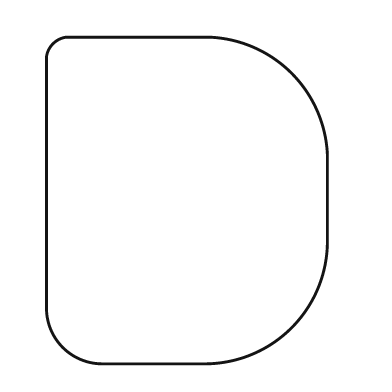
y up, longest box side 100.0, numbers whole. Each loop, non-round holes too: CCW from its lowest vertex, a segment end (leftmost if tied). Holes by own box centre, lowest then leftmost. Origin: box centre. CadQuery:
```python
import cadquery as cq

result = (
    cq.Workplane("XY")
    .moveTo(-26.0, -50.0)
    .lineTo(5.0, -50.0)
    .threePointArc((32.0, -39.0), (43.0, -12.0))
    .lineTo(43.0, 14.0)
    .threePointArc((32.0, 39.0), (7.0, 50.0))
    .lineTo(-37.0, 50.0)
    .threePointArc((-41.0, 48.0), (-43.0, 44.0))
    .lineTo(-43.0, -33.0)
    .threePointArc((-38.0, -45.0), (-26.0, -50.0))
    .close()
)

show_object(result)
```